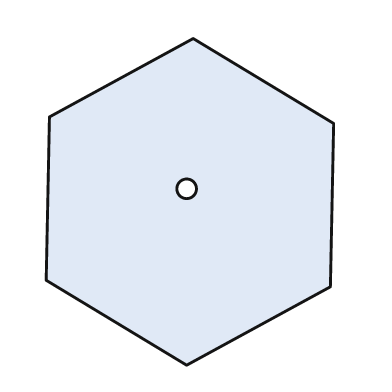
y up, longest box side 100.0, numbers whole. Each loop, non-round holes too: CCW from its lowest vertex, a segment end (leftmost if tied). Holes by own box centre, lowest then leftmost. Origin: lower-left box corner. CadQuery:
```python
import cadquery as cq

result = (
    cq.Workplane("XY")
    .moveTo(43.0, 0.0)
    .lineTo(87.0, 24.0)
    .lineTo(88.0, 74.0)
    .lineTo(45.0, 100.0)
    .lineTo(1.0, 76.0)
    .lineTo(0.0, 26.0)
    .close()
    .moveTo(43.0, 54.0)
    .circle(3.0)
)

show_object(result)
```